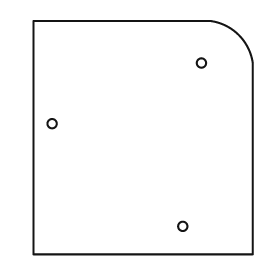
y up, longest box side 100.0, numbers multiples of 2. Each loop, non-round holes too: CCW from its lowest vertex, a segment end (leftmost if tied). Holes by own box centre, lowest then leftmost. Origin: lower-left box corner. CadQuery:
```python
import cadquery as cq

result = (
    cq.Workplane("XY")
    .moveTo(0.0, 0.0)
    .lineTo(94.0, 0.0)
    .lineTo(94.0, 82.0)
    .threePointArc((88.0, 94.0), (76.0, 100.0))
    .lineTo(0.0, 100.0)
    .close()
    .moveTo(64.0, 12.0)
    .circle(2.0)
    .moveTo(8.0, 56.0)
    .circle(2.0)
    .moveTo(72.0, 82.0)
    .circle(2.0)
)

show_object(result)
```